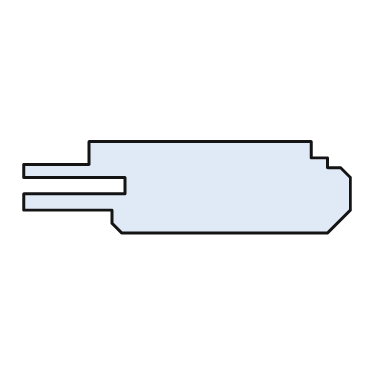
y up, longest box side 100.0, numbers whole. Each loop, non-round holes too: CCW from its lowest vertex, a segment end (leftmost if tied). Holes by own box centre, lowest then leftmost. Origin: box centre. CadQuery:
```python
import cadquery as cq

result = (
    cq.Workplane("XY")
    .moveTo(-20.0, -14.0)
    .lineTo(43.0, -14.0)
    .lineTo(50.0, -7.0)
    .lineTo(50.0, 3.0)
    .lineTo(47.0, 6.0)
    .lineTo(43.0, 6.0)
    .lineTo(43.0, 9.0)
    .lineTo(38.0, 9.0)
    .lineTo(38.0, 14.0)
    .lineTo(-30.0, 14.0)
    .lineTo(-30.0, 7.0)
    .lineTo(-50.0, 7.0)
    .lineTo(-50.0, 3.0)
    .lineTo(-19.0, 3.0)
    .lineTo(-19.0, -2.0)
    .lineTo(-50.0, -2.0)
    .lineTo(-50.0, -7.0)
    .lineTo(-23.0, -7.0)
    .lineTo(-23.0, -11.0)
    .close()
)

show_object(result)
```